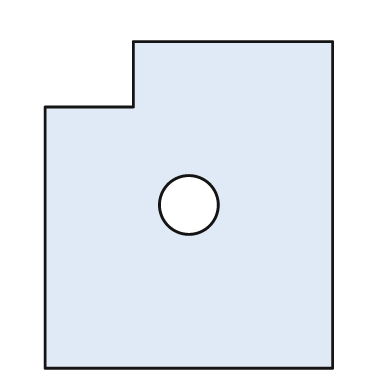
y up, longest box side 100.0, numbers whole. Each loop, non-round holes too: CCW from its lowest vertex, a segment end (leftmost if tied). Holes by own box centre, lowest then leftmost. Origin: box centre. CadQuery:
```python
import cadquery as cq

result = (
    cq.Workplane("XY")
    .moveTo(-44.0, -50.0)
    .lineTo(44.0, -50.0)
    .lineTo(44.0, 50.0)
    .lineTo(-17.0, 50.0)
    .lineTo(-17.0, 30.0)
    .lineTo(-44.0, 30.0)
    .close()
    .moveTo(0.0, 0.0)
    .circle(9.0)
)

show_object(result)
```